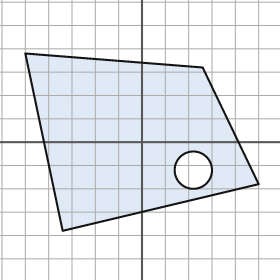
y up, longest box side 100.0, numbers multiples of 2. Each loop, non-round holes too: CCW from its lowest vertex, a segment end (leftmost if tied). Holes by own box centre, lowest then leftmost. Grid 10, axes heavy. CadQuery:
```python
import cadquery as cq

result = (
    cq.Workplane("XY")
    .moveTo(-34.0, -38.0)
    .lineTo(50.0, -18.0)
    .lineTo(26.0, 32.0)
    .lineTo(-50.0, 38.0)
    .close()
    .moveTo(22.0, -12.0)
    .circle(8.0)
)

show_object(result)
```